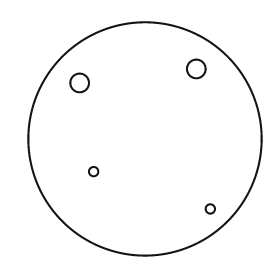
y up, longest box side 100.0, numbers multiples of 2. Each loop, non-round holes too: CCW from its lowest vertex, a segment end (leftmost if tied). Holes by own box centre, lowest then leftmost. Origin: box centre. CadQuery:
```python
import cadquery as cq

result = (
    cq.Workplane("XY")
    .moveTo(0.0, 0.0)
    .circle(50.0)
    .moveTo(28.0, -30.0)
    .circle(2.0)
    .moveTo(-22.0, -14.0)
    .circle(2.0)
    .moveTo(-28.0, 24.0)
    .circle(4.0)
    .moveTo(22.0, 30.0)
    .circle(4.0)
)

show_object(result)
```